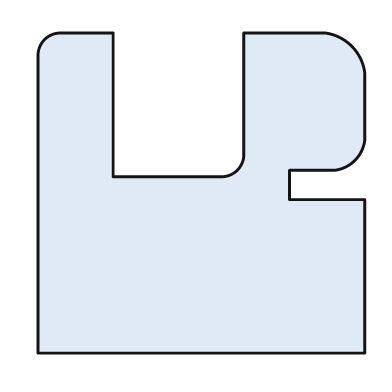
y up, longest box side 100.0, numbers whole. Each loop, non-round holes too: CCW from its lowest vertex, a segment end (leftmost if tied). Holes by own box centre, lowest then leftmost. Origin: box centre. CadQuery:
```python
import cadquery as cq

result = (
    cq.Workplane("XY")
    .moveTo(-50.0, -49.0)
    .lineTo(50.0, -49.0)
    .lineTo(50.0, -2.0)
    .lineTo(27.0, -2.0)
    .lineTo(27.0, 7.0)
    .lineTo(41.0, 7.0)
    .threePointArc((47.0, 10.0), (50.0, 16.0))
    .lineTo(50.0, 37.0)
    .threePointArc((46.0, 45.0), (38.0, 49.0))
    .lineTo(13.0, 49.0)
    .lineTo(13.0, 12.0)
    .threePointArc((11.0, 7.0), (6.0, 5.0))
    .lineTo(-27.0, 5.0)
    .lineTo(-27.0, 49.0)
    .lineTo(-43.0, 49.0)
    .threePointArc((-48.0, 47.0), (-50.0, 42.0))
    .close()
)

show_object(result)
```